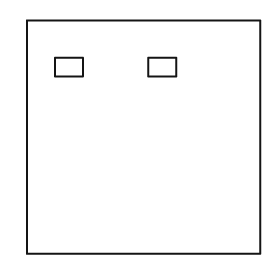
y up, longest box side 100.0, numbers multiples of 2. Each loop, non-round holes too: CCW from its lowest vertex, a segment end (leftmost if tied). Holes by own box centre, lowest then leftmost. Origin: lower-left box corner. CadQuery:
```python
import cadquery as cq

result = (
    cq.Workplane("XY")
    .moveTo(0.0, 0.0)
    .lineTo(100.0, 0.0)
    .lineTo(100.0, 100.0)
    .lineTo(0.0, 100.0)
    .close()
    .moveTo(12.0, 76.0)
    .lineTo(24.0, 76.0)
    .lineTo(24.0, 84.0)
    .lineTo(12.0, 84.0)
    .close()
    .moveTo(52.0, 76.0)
    .lineTo(64.0, 76.0)
    .lineTo(64.0, 84.0)
    .lineTo(52.0, 84.0)
    .close()
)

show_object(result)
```